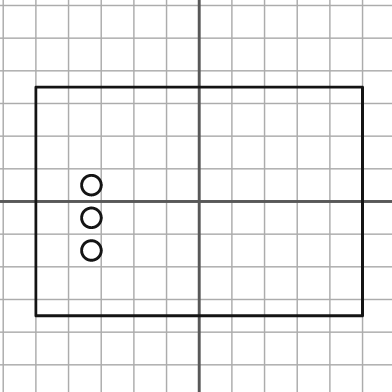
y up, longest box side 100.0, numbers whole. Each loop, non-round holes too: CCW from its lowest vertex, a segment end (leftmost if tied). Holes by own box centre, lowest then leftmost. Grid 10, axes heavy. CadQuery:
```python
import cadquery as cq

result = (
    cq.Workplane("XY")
    .moveTo(-50.0, -35.0)
    .lineTo(50.0, -35.0)
    .lineTo(50.0, 35.0)
    .lineTo(-50.0, 35.0)
    .close()
    .moveTo(-33.0, -15.0)
    .circle(3.0)
    .moveTo(-33.0, -5.0)
    .circle(3.0)
    .moveTo(-33.0, 5.0)
    .circle(3.0)
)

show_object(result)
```